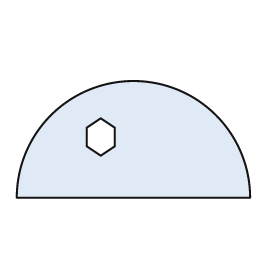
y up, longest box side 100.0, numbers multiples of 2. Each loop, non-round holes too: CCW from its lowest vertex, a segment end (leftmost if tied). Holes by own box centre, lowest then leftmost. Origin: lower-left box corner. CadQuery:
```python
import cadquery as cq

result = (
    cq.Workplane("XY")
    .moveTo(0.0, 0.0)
    .lineTo(100.0, 0.0)
    .threePointArc((50.0, 50.0), (0.0, 0.0))
    .close()
    .moveTo(36.0, 18.0)
    .lineTo(42.0, 22.0)
    .lineTo(42.0, 30.0)
    .lineTo(36.0, 34.0)
    .lineTo(30.0, 30.0)
    .lineTo(30.0, 22.0)
    .close()
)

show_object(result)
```